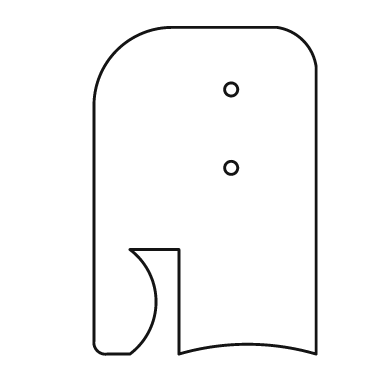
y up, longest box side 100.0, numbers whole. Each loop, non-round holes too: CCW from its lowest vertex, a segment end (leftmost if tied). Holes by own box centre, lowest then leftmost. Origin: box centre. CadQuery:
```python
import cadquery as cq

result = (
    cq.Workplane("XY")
    .moveTo(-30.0, -50.0)
    .lineTo(-23.0, -50.0)
    .threePointArc((-15.0, -34.0), (-23.0, -18.0))
    .lineTo(-8.0, -18.0)
    .lineTo(-8.0, -50.0)
    .threePointArc((13.0, -47.0), (34.0, -50.0))
    .lineTo(34.0, 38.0)
    .threePointArc((30.0, 46.0), (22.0, 50.0))
    .lineTo(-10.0, 50.0)
    .threePointArc((-27.0, 43.0), (-34.0, 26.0))
    .lineTo(-34.0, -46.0)
    .threePointArc((-33.0, -49.0), (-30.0, -50.0))
    .close()
    .moveTo(8.0, 7.0)
    .circle(2.0)
    .moveTo(8.0, 31.0)
    .circle(2.0)
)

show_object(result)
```